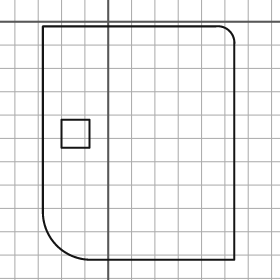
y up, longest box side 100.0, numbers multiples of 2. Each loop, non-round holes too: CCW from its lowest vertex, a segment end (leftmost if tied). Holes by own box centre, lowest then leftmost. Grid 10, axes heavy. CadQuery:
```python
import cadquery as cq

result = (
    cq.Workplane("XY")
    .moveTo(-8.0, -102.0)
    .lineTo(54.0, -102.0)
    .lineTo(54.0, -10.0)
    .threePointArc((52.0, -4.0), (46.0, -2.0))
    .lineTo(-28.0, -2.0)
    .lineTo(-28.0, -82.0)
    .threePointArc((-22.0, -96.0), (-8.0, -102.0))
    .close()
    .moveTo(-20.0, -54.0)
    .lineTo(-8.0, -54.0)
    .lineTo(-8.0, -42.0)
    .lineTo(-20.0, -42.0)
    .close()
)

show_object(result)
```